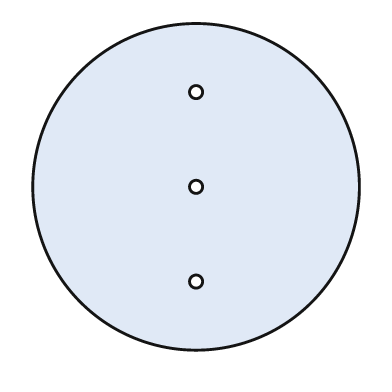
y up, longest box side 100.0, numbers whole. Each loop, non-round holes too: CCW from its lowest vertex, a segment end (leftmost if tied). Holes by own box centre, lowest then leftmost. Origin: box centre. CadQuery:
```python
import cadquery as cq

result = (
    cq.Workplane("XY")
    .moveTo(0.0, 0.0)
    .circle(50.0)
    .moveTo(0.0, -29.0)
    .circle(2.0)
    .moveTo(0.0, 0.0)
    .circle(2.0)
    .moveTo(0.0, 29.0)
    .circle(2.0)
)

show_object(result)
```